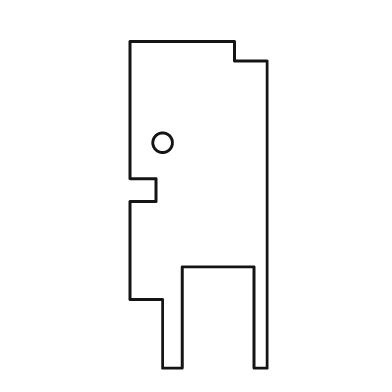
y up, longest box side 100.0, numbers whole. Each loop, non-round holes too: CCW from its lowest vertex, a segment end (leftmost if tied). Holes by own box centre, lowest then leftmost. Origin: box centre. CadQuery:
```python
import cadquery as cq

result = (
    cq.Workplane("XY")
    .moveTo(-11.0, -50.0)
    .lineTo(-5.0, -50.0)
    .lineTo(-5.0, -19.0)
    .lineTo(17.0, -19.0)
    .lineTo(17.0, -50.0)
    .lineTo(21.0, -50.0)
    .lineTo(21.0, 44.0)
    .lineTo(11.0, 44.0)
    .lineTo(11.0, 50.0)
    .lineTo(-21.0, 50.0)
    .lineTo(-21.0, 8.0)
    .lineTo(-13.0, 8.0)
    .lineTo(-13.0, 1.0)
    .lineTo(-21.0, 1.0)
    .lineTo(-21.0, -29.0)
    .lineTo(-11.0, -29.0)
    .close()
    .moveTo(-11.0, 19.0)
    .circle(3.0)
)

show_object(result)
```